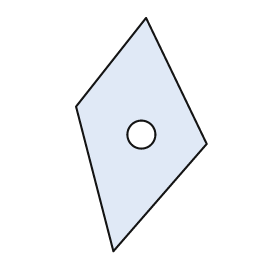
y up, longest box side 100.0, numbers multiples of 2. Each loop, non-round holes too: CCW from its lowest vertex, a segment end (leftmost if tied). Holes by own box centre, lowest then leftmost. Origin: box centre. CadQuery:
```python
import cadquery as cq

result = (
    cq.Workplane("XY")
    .moveTo(-12.0, -50.0)
    .lineTo(28.0, -4.0)
    .lineTo(2.0, 50.0)
    .lineTo(-28.0, 12.0)
    .close()
    .moveTo(0.0, 0.0)
    .circle(6.0)
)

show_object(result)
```